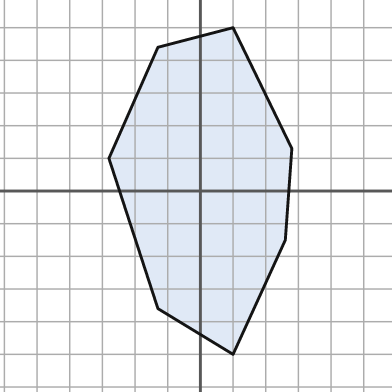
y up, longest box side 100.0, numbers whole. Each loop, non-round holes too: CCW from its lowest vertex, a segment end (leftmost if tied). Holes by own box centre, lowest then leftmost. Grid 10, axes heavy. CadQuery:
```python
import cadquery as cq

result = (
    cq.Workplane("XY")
    .moveTo(10.0, -50.0)
    .lineTo(26.0, -15.0)
    .lineTo(28.0, 13.0)
    .lineTo(10.0, 50.0)
    .lineTo(-13.0, 44.0)
    .lineTo(-28.0, 10.0)
    .lineTo(-13.0, -36.0)
    .close()
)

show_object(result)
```